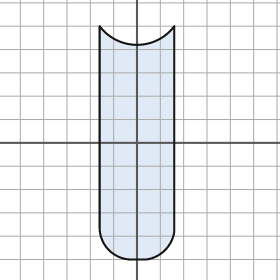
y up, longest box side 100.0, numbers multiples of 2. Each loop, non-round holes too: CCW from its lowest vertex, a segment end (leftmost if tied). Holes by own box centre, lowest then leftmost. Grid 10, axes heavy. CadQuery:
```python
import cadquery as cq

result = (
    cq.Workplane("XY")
    .moveTo(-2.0, -50.0)
    .lineTo(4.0, -50.0)
    .threePointArc((12.0, -46.0), (16.0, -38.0))
    .lineTo(16.0, 50.0)
    .threePointArc((0.0, 42.0), (-16.0, 50.0))
    .lineTo(-16.0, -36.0)
    .threePointArc((-12.0, -46.0), (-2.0, -50.0))
    .close()
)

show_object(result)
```